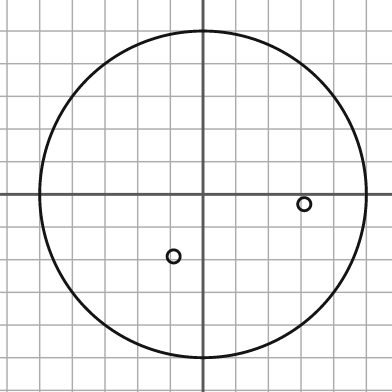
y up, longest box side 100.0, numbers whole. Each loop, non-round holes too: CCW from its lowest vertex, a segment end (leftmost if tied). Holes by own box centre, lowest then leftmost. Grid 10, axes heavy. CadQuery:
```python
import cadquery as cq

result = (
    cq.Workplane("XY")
    .moveTo(0.0, 0.0)
    .circle(50.0)
    .moveTo(-9.0, -19.0)
    .circle(2.0)
    .moveTo(31.0, -3.0)
    .circle(2.0)
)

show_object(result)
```